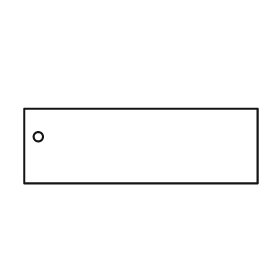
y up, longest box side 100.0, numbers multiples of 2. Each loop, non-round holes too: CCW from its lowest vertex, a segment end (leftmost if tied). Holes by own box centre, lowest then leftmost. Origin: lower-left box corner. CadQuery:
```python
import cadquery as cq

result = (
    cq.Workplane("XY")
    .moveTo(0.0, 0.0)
    .lineTo(100.0, 0.0)
    .lineTo(100.0, 32.0)
    .lineTo(0.0, 32.0)
    .close()
    .moveTo(6.0, 20.0)
    .circle(2.0)
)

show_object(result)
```